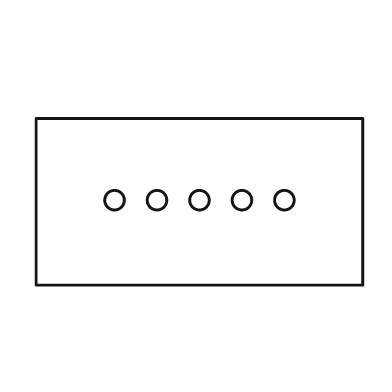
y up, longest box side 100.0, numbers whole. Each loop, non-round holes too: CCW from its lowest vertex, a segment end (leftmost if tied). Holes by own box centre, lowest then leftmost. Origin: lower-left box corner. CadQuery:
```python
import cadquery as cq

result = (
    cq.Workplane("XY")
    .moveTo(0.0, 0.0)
    .lineTo(100.0, 0.0)
    .lineTo(100.0, 51.0)
    .lineTo(0.0, 51.0)
    .close()
    .moveTo(24.0, 26.0)
    .circle(3.0)
    .moveTo(37.0, 26.0)
    .circle(3.0)
    .moveTo(50.0, 26.0)
    .circle(3.0)
    .moveTo(63.0, 26.0)
    .circle(3.0)
    .moveTo(76.0, 26.0)
    .circle(3.0)
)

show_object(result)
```